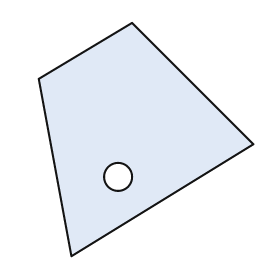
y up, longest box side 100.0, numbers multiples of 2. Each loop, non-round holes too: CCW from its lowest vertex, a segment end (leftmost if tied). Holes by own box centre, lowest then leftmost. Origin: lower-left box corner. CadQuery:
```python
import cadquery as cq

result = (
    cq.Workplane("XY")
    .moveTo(14.0, 0.0)
    .lineTo(92.0, 48.0)
    .lineTo(40.0, 100.0)
    .lineTo(0.0, 76.0)
    .close()
    .moveTo(34.0, 34.0)
    .circle(6.0)
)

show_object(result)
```